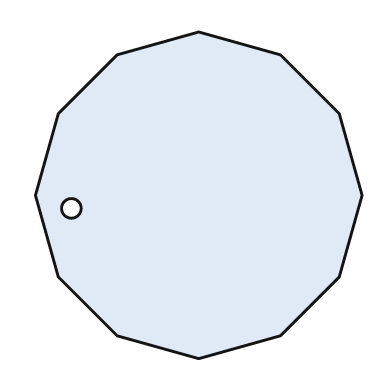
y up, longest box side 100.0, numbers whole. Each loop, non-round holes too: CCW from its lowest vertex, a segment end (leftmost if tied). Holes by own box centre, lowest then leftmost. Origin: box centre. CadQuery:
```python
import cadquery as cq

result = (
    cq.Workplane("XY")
    .moveTo(0.0, -50.0)
    .lineTo(25.0, -43.0)
    .lineTo(43.0, -25.0)
    .lineTo(50.0, 0.0)
    .lineTo(43.0, 25.0)
    .lineTo(25.0, 43.0)
    .lineTo(0.0, 50.0)
    .lineTo(-25.0, 43.0)
    .lineTo(-43.0, 25.0)
    .lineTo(-50.0, 0.0)
    .lineTo(-43.0, -25.0)
    .lineTo(-25.0, -43.0)
    .close()
    .moveTo(-39.0, -4.0)
    .circle(3.0)
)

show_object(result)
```